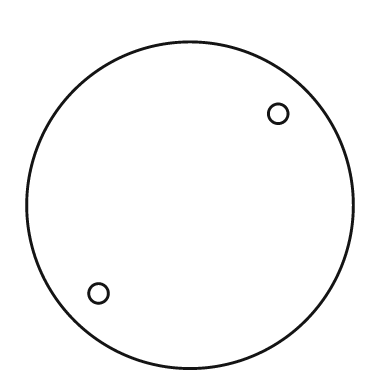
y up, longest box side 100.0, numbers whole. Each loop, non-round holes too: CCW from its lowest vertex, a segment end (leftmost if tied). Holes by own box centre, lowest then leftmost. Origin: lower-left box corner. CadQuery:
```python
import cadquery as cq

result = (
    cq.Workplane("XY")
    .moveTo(50.0, 50.0)
    .circle(50.0)
    .moveTo(22.0, 23.0)
    .circle(3.0)
    .moveTo(77.0, 78.0)
    .circle(3.0)
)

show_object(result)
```